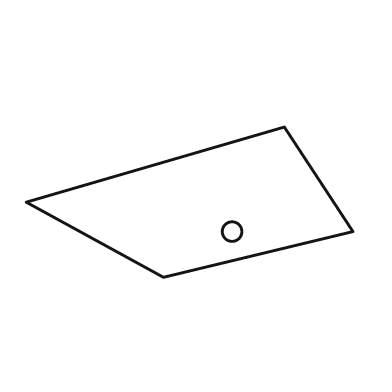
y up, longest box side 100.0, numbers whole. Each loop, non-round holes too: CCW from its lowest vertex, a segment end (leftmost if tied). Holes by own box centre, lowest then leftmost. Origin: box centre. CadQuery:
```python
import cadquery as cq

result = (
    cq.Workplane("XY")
    .moveTo(-8.0, -23.0)
    .lineTo(50.0, -9.0)
    .lineTo(29.0, 23.0)
    .lineTo(-50.0, 0.0)
    .close()
    .moveTo(13.0, -9.0)
    .circle(3.0)
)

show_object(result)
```